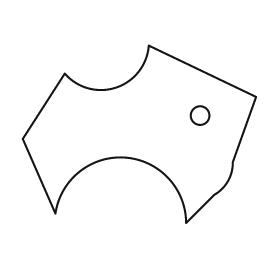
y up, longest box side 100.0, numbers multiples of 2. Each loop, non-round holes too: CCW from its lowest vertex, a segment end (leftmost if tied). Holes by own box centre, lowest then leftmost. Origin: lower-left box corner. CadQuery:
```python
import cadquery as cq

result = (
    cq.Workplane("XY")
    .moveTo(70.0, 0.0)
    .lineTo(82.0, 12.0)
    .threePointArc((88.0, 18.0), (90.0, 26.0))
    .lineTo(100.0, 54.0)
    .lineTo(54.0, 76.0)
    .threePointArc((40.0, 58.0), (18.0, 64.0))
    .lineTo(0.0, 36.0)
    .lineTo(14.0, 4.0)
    .threePointArc((44.0, 28.0), (70.0, 0.0))
    .close()
    .moveTo(76.0, 46.0)
    .circle(4.0)
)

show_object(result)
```